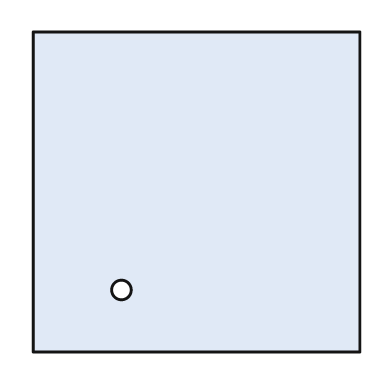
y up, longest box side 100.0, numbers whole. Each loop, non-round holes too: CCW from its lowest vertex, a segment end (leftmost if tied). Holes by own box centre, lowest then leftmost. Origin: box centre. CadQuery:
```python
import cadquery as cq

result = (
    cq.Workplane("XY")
    .moveTo(-50.0, -49.0)
    .lineTo(50.0, -49.0)
    .lineTo(50.0, 49.0)
    .lineTo(-50.0, 49.0)
    .close()
    .moveTo(-23.0, -30.0)
    .circle(3.0)
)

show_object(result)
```